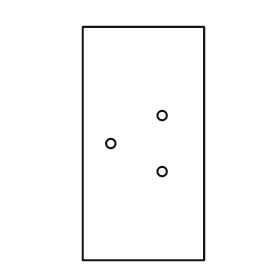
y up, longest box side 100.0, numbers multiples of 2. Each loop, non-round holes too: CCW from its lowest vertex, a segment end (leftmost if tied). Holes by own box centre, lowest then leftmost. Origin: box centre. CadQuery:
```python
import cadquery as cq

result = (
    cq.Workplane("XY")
    .moveTo(-26.0, -50.0)
    .lineTo(26.0, -50.0)
    .lineTo(26.0, 50.0)
    .lineTo(-26.0, 50.0)
    .close()
    .moveTo(8.0, -12.0)
    .circle(2.0)
    .moveTo(-14.0, 0.0)
    .circle(2.0)
    .moveTo(8.0, 12.0)
    .circle(2.0)
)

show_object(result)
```